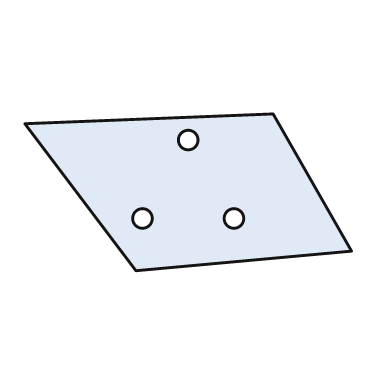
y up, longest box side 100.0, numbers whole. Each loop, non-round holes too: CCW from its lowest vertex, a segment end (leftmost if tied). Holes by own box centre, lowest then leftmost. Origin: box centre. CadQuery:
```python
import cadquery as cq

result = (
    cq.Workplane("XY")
    .moveTo(-16.0, -24.0)
    .lineTo(50.0, -18.0)
    .lineTo(26.0, 24.0)
    .lineTo(-50.0, 21.0)
    .close()
    .moveTo(-14.0, -8.0)
    .circle(3.0)
    .moveTo(14.0, -8.0)
    .circle(3.0)
    .moveTo(0.0, 16.0)
    .circle(3.0)
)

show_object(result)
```